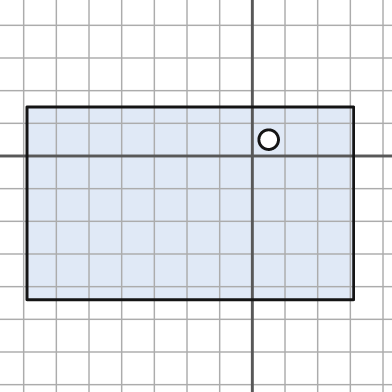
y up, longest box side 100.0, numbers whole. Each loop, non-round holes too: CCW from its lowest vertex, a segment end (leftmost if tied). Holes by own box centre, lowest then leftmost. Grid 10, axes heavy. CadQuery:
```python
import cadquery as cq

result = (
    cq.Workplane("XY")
    .moveTo(-69.0, -44.0)
    .lineTo(31.0, -44.0)
    .lineTo(31.0, 15.0)
    .lineTo(-69.0, 15.0)
    .close()
    .moveTo(5.0, 5.0)
    .circle(3.0)
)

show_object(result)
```